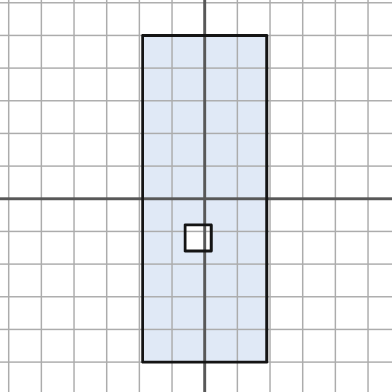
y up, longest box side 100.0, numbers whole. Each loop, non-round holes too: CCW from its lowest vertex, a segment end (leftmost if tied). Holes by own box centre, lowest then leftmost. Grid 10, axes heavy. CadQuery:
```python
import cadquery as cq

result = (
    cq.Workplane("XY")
    .moveTo(-19.0, -50.0)
    .lineTo(19.0, -50.0)
    .lineTo(19.0, 50.0)
    .lineTo(-19.0, 50.0)
    .close()
    .moveTo(-6.0, -16.0)
    .lineTo(2.0, -16.0)
    .lineTo(2.0, -8.0)
    .lineTo(-6.0, -8.0)
    .close()
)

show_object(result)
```